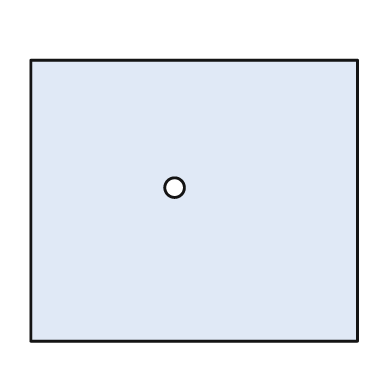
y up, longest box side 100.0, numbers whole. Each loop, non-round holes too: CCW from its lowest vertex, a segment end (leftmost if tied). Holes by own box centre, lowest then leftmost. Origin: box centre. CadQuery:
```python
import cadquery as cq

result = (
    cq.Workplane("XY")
    .moveTo(-50.0, -43.0)
    .lineTo(50.0, -43.0)
    .lineTo(50.0, 43.0)
    .lineTo(-50.0, 43.0)
    .close()
    .moveTo(-6.0, 4.0)
    .circle(3.0)
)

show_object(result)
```